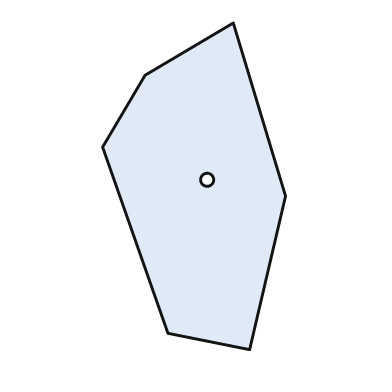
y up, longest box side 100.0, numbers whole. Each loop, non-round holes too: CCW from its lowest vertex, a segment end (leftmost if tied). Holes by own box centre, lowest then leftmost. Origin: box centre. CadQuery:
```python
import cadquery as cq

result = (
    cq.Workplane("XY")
    .moveTo(17.0, -50.0)
    .lineTo(28.0, -3.0)
    .lineTo(12.0, 50.0)
    .lineTo(-15.0, 34.0)
    .lineTo(-28.0, 12.0)
    .lineTo(-8.0, -45.0)
    .close()
    .moveTo(4.0, 2.0)
    .circle(2.0)
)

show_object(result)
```